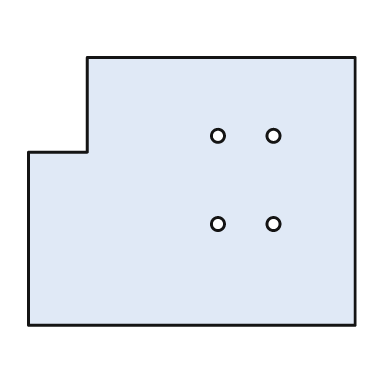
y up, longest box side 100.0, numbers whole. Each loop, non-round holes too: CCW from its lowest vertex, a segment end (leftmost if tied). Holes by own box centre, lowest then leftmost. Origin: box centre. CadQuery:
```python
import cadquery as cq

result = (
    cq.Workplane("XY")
    .moveTo(-50.0, -41.0)
    .lineTo(50.0, -41.0)
    .lineTo(50.0, 41.0)
    .lineTo(-32.0, 41.0)
    .lineTo(-32.0, 12.0)
    .lineTo(-50.0, 12.0)
    .close()
    .moveTo(8.0, -10.0)
    .circle(2.0)
    .moveTo(25.0, -10.0)
    .circle(2.0)
    .moveTo(8.0, 17.0)
    .circle(2.0)
    .moveTo(25.0, 17.0)
    .circle(2.0)
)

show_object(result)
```